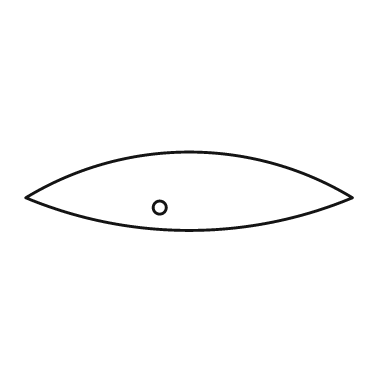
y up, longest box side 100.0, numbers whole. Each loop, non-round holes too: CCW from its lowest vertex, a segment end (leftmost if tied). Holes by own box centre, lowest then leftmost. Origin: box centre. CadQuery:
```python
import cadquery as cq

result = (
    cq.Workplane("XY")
    .moveTo(-50.0, -2.0)
    .threePointArc((0.0, -12.0), (50.0, -2.0))
    .threePointArc((0.0, 12.0), (-50.0, -2.0))
    .close()
    .moveTo(-9.0, -5.0)
    .circle(2.0)
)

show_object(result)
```